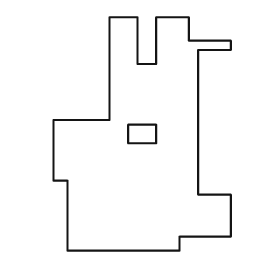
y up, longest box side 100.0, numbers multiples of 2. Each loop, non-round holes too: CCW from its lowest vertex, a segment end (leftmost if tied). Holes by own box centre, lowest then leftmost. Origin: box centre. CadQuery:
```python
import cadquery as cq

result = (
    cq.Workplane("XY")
    .moveTo(-32.0, -50.0)
    .lineTo(16.0, -50.0)
    .lineTo(16.0, -44.0)
    .lineTo(38.0, -44.0)
    .lineTo(38.0, -26.0)
    .lineTo(24.0, -26.0)
    .lineTo(24.0, 36.0)
    .lineTo(38.0, 36.0)
    .lineTo(38.0, 40.0)
    .lineTo(20.0, 40.0)
    .lineTo(20.0, 50.0)
    .lineTo(6.0, 50.0)
    .lineTo(6.0, 30.0)
    .lineTo(-2.0, 30.0)
    .lineTo(-2.0, 50.0)
    .lineTo(-14.0, 50.0)
    .lineTo(-14.0, 6.0)
    .lineTo(-38.0, 6.0)
    .lineTo(-38.0, -20.0)
    .lineTo(-32.0, -20.0)
    .close()
    .moveTo(-6.0, -4.0)
    .lineTo(6.0, -4.0)
    .lineTo(6.0, 4.0)
    .lineTo(-6.0, 4.0)
    .close()
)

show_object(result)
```